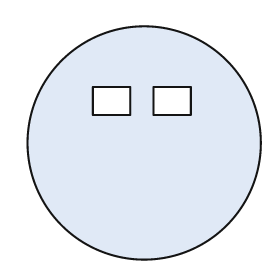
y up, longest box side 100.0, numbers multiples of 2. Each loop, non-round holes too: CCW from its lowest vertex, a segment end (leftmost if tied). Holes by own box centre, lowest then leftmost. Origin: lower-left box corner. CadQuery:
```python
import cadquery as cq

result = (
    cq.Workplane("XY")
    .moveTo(50.0, 50.0)
    .circle(50.0)
    .moveTo(28.0, 62.0)
    .lineTo(44.0, 62.0)
    .lineTo(44.0, 74.0)
    .lineTo(28.0, 74.0)
    .close()
    .moveTo(54.0, 62.0)
    .lineTo(70.0, 62.0)
    .lineTo(70.0, 74.0)
    .lineTo(54.0, 74.0)
    .close()
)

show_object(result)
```